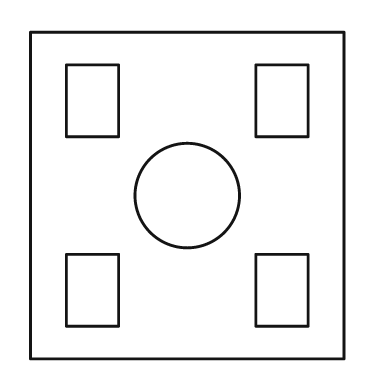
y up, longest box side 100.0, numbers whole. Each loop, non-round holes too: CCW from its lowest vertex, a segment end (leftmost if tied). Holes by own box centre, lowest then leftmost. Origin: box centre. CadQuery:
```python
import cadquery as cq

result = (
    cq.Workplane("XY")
    .moveTo(-48.0, -50.0)
    .lineTo(48.0, -50.0)
    .lineTo(48.0, 50.0)
    .lineTo(-48.0, 50.0)
    .close()
    .moveTo(-37.0, -40.0)
    .lineTo(-21.0, -40.0)
    .lineTo(-21.0, -18.0)
    .lineTo(-37.0, -18.0)
    .close()
    .moveTo(21.0, -40.0)
    .lineTo(37.0, -40.0)
    .lineTo(37.0, -18.0)
    .lineTo(21.0, -18.0)
    .close()
    .moveTo(0.0, 0.0)
    .circle(16.0)
    .moveTo(-37.0, 18.0)
    .lineTo(-21.0, 18.0)
    .lineTo(-21.0, 40.0)
    .lineTo(-37.0, 40.0)
    .close()
    .moveTo(21.0, 18.0)
    .lineTo(37.0, 18.0)
    .lineTo(37.0, 40.0)
    .lineTo(21.0, 40.0)
    .close()
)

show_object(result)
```